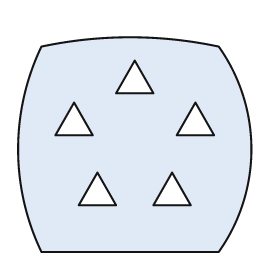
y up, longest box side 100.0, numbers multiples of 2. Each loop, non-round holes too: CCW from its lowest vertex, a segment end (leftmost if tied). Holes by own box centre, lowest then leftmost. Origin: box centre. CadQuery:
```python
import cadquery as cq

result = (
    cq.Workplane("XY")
    .moveTo(-40.0, -46.0)
    .lineTo(36.0, -46.0)
    .threePointArc((50.0, -2.0), (36.0, 42.0))
    .threePointArc((-2.0, 46.0), (-40.0, 42.0))
    .threePointArc((-50.0, -2.0), (-40.0, -46.0))
    .close()
    .moveTo(-24.0, -26.0)
    .lineTo(-8.0, -26.0)
    .lineTo(-16.0, -12.0)
    .close()
    .moveTo(8.0, -26.0)
    .lineTo(24.0, -26.0)
    .lineTo(16.0, -12.0)
    .close()
    .moveTo(-34.0, 4.0)
    .lineTo(-18.0, 4.0)
    .lineTo(-26.0, 18.0)
    .close()
    .moveTo(18.0, 4.0)
    .lineTo(34.0, 4.0)
    .lineTo(26.0, 18.0)
    .close()
    .moveTo(-8.0, 22.0)
    .lineTo(8.0, 22.0)
    .lineTo(0.0, 36.0)
    .close()
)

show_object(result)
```